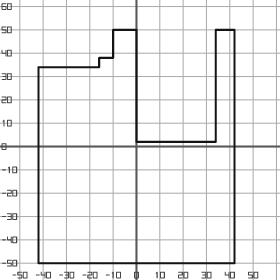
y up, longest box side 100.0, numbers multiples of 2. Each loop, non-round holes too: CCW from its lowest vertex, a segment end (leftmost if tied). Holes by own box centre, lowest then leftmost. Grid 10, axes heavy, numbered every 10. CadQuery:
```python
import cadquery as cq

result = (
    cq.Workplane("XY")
    .moveTo(-42.0, -50.0)
    .lineTo(42.0, -50.0)
    .lineTo(42.0, 50.0)
    .lineTo(34.0, 50.0)
    .lineTo(34.0, 2.0)
    .lineTo(0.0, 2.0)
    .lineTo(0.0, 50.0)
    .lineTo(-10.0, 50.0)
    .lineTo(-10.0, 38.0)
    .lineTo(-16.0, 38.0)
    .lineTo(-16.0, 34.0)
    .lineTo(-42.0, 34.0)
    .close()
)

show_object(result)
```